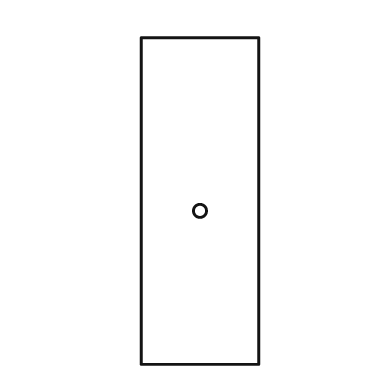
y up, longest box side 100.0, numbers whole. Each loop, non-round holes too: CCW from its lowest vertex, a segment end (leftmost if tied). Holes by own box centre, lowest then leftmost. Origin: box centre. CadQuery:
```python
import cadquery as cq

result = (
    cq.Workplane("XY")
    .moveTo(-18.0, -50.0)
    .lineTo(18.0, -50.0)
    .lineTo(18.0, 50.0)
    .lineTo(-18.0, 50.0)
    .close()
    .moveTo(0.0, -3.0)
    .circle(2.0)
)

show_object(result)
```